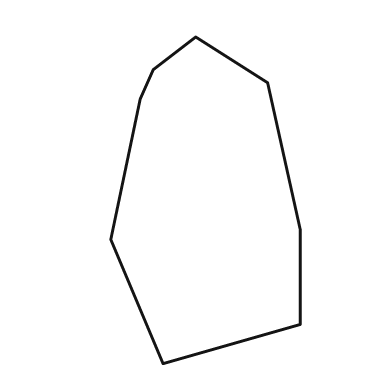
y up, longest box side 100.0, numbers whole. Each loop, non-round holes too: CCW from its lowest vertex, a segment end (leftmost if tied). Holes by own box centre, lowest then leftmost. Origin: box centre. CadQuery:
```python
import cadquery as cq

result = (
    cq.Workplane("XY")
    .moveTo(-13.0, -50.0)
    .lineTo(29.0, -38.0)
    .lineTo(29.0, -9.0)
    .lineTo(19.0, 36.0)
    .lineTo(-3.0, 50.0)
    .lineTo(-16.0, 40.0)
    .lineTo(-20.0, 31.0)
    .lineTo(-29.0, -12.0)
    .close()
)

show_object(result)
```